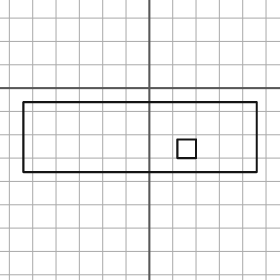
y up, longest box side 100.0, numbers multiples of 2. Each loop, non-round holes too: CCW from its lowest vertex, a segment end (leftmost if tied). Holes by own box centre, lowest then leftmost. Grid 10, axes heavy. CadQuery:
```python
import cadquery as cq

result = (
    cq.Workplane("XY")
    .moveTo(-54.0, -36.0)
    .lineTo(46.0, -36.0)
    .lineTo(46.0, -6.0)
    .lineTo(-54.0, -6.0)
    .close()
    .moveTo(12.0, -30.0)
    .lineTo(20.0, -30.0)
    .lineTo(20.0, -22.0)
    .lineTo(12.0, -22.0)
    .close()
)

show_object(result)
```